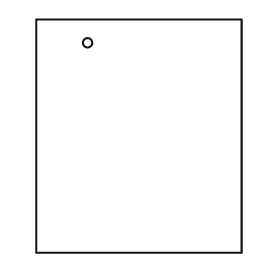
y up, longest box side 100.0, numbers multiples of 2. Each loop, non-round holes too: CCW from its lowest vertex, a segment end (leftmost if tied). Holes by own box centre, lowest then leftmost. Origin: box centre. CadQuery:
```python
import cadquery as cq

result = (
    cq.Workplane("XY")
    .moveTo(-44.0, -50.0)
    .lineTo(44.0, -50.0)
    .lineTo(44.0, 50.0)
    .lineTo(-44.0, 50.0)
    .close()
    .moveTo(-22.0, 40.0)
    .circle(2.0)
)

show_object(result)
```